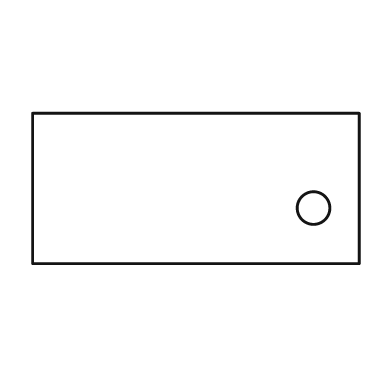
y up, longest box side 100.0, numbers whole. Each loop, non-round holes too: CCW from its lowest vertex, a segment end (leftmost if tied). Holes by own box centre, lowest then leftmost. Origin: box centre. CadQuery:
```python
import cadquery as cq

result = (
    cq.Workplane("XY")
    .moveTo(-50.0, -23.0)
    .lineTo(50.0, -23.0)
    .lineTo(50.0, 23.0)
    .lineTo(-50.0, 23.0)
    .close()
    .moveTo(36.0, -6.0)
    .circle(5.0)
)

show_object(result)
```